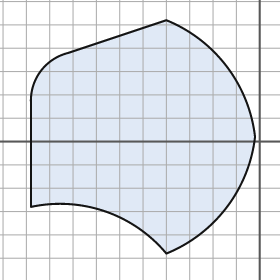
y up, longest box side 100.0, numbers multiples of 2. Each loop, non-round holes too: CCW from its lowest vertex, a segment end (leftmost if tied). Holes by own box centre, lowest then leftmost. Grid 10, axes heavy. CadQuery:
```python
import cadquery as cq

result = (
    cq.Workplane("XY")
    .moveTo(-40.0, -48.0)
    .threePointArc((-14.0, -28.0), (-2.0, 2.0))
    .threePointArc((-14.0, 32.0), (-40.0, 52.0))
    .lineTo(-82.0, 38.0)
    .threePointArc((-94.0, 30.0), (-98.0, 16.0))
    .lineTo(-98.0, -28.0)
    .threePointArc((-66.0, -30.0), (-40.0, -48.0))
    .close()
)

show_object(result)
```